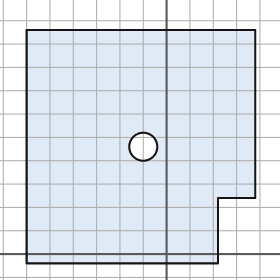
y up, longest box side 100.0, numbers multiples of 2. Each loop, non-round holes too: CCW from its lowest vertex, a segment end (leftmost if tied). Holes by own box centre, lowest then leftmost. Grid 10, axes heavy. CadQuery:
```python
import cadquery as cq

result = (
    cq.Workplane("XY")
    .moveTo(-60.0, -4.0)
    .lineTo(22.0, -4.0)
    .lineTo(22.0, 24.0)
    .lineTo(38.0, 24.0)
    .lineTo(38.0, 96.0)
    .lineTo(-60.0, 96.0)
    .close()
    .moveTo(-10.0, 46.0)
    .circle(6.0)
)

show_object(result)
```